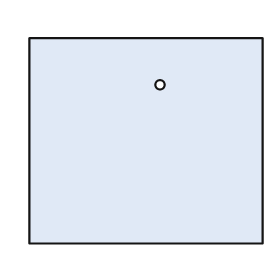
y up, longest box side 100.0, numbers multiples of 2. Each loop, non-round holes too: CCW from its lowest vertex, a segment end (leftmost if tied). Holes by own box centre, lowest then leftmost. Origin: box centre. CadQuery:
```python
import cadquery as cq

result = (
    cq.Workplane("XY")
    .moveTo(-50.0, -44.0)
    .lineTo(50.0, -44.0)
    .lineTo(50.0, 44.0)
    .lineTo(-50.0, 44.0)
    .close()
    .moveTo(6.0, 24.0)
    .circle(2.0)
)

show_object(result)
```